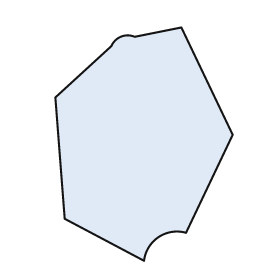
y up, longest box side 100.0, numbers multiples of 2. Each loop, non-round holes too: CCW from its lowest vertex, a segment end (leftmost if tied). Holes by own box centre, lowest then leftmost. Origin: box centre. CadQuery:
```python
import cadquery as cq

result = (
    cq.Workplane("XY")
    .moveTo(0.0, -50.0)
    .threePointArc((6.0, -40.0), (18.0, -38.0))
    .lineTo(38.0, 4.0)
    .lineTo(16.0, 50.0)
    .lineTo(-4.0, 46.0)
    .threePointArc((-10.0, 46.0), (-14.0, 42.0))
    .lineTo(-38.0, 20.0)
    .lineTo(-34.0, -32.0)
    .close()
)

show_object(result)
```